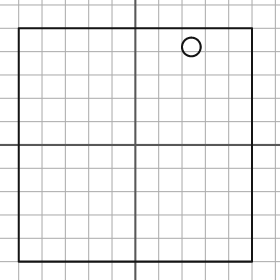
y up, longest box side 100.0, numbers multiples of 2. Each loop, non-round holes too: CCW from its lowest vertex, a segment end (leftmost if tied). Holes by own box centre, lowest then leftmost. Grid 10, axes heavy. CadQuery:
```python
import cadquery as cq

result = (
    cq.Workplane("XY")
    .moveTo(-50.0, -50.0)
    .lineTo(50.0, -50.0)
    .lineTo(50.0, 50.0)
    .lineTo(-50.0, 50.0)
    .close()
    .moveTo(24.0, 42.0)
    .circle(4.0)
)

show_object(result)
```